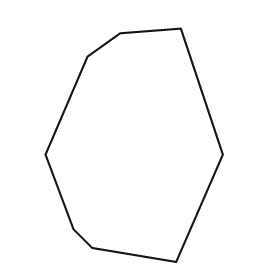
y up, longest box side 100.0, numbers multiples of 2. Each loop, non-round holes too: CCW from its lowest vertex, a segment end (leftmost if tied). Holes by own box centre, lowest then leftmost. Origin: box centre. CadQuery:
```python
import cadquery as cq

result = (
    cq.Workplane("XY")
    .moveTo(18.0, -50.0)
    .lineTo(38.0, -4.0)
    .lineTo(20.0, 50.0)
    .lineTo(-6.0, 48.0)
    .lineTo(-20.0, 38.0)
    .lineTo(-38.0, -4.0)
    .lineTo(-26.0, -36.0)
    .lineTo(-18.0, -44.0)
    .close()
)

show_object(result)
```